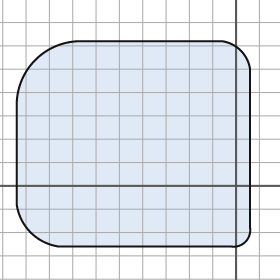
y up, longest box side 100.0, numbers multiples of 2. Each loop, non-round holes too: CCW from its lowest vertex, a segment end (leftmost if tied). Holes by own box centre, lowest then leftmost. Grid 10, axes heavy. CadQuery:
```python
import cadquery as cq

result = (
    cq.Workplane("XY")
    .moveTo(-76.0, -26.0)
    .lineTo(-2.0, -26.0)
    .threePointArc((4.0, -24.0), (6.0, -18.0))
    .lineTo(6.0, 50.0)
    .threePointArc((2.0, 58.0), (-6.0, 62.0))
    .lineTo(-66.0, 62.0)
    .threePointArc((-86.0, 54.0), (-94.0, 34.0))
    .lineTo(-94.0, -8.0)
    .threePointArc((-88.0, -20.0), (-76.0, -26.0))
    .close()
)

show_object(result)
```